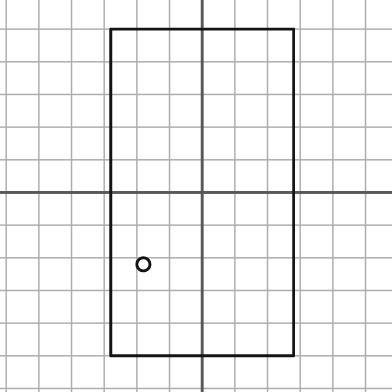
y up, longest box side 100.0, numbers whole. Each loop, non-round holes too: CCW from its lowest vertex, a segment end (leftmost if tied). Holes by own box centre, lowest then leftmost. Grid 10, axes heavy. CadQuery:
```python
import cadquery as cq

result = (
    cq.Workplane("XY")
    .moveTo(-28.0, -50.0)
    .lineTo(28.0, -50.0)
    .lineTo(28.0, 50.0)
    .lineTo(-28.0, 50.0)
    .close()
    .moveTo(-18.0, -22.0)
    .circle(2.0)
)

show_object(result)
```